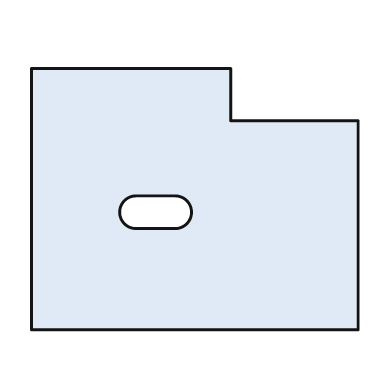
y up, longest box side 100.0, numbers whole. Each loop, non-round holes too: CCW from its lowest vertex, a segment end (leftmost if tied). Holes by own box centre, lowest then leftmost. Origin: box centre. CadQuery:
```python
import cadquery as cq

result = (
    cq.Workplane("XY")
    .moveTo(-50.0, -40.0)
    .lineTo(50.0, -40.0)
    .lineTo(50.0, 24.0)
    .lineTo(11.0, 24.0)
    .lineTo(11.0, 40.0)
    .lineTo(-50.0, 40.0)
    .close()
    .moveTo(-18.0, -9.0)
    .lineTo(-6.0, -9.0)
    .threePointArc((-1.0, -4.0), (-6.0, 1.0))
    .lineTo(-18.0, 1.0)
    .threePointArc((-23.0, -4.0), (-18.0, -9.0))
    .close()
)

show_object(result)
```